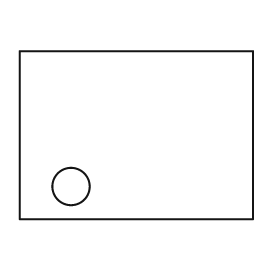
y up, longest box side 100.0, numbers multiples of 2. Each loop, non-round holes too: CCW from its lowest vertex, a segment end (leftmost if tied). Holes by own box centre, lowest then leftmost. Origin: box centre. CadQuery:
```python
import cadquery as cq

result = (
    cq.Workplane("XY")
    .moveTo(-50.0, -36.0)
    .lineTo(50.0, -36.0)
    .lineTo(50.0, 36.0)
    .lineTo(-50.0, 36.0)
    .close()
    .moveTo(-28.0, -22.0)
    .circle(8.0)
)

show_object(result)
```